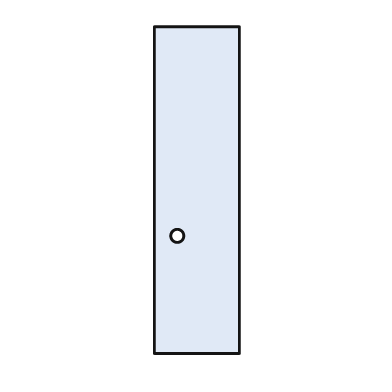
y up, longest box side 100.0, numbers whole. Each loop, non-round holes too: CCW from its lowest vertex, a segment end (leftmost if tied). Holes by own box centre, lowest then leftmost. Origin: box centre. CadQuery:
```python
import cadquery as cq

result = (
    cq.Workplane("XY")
    .moveTo(-13.0, -50.0)
    .lineTo(13.0, -50.0)
    .lineTo(13.0, 50.0)
    .lineTo(-13.0, 50.0)
    .close()
    .moveTo(-6.0, -14.0)
    .circle(2.0)
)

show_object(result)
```